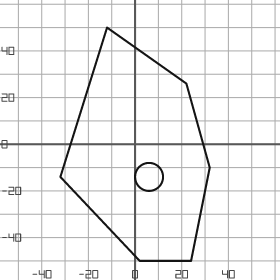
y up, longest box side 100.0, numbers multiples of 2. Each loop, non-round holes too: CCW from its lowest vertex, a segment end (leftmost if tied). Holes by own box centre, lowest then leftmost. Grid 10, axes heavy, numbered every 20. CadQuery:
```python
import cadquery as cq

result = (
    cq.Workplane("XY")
    .moveTo(2.0, -50.0)
    .lineTo(24.0, -50.0)
    .lineTo(32.0, -10.0)
    .lineTo(22.0, 26.0)
    .lineTo(-12.0, 50.0)
    .lineTo(-32.0, -14.0)
    .close()
    .moveTo(6.0, -14.0)
    .circle(6.0)
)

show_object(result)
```